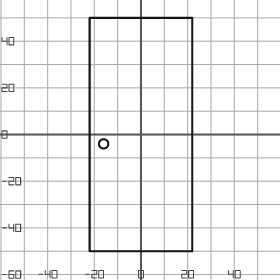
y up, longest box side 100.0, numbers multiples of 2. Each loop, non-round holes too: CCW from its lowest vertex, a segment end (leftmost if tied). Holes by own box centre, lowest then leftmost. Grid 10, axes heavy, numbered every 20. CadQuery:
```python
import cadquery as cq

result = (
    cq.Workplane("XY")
    .moveTo(-22.0, -50.0)
    .lineTo(22.0, -50.0)
    .lineTo(22.0, 50.0)
    .lineTo(-22.0, 50.0)
    .close()
    .moveTo(-16.0, -4.0)
    .circle(2.0)
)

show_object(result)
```